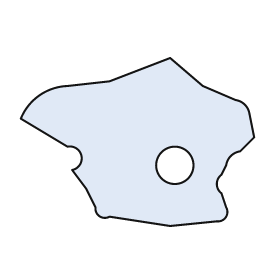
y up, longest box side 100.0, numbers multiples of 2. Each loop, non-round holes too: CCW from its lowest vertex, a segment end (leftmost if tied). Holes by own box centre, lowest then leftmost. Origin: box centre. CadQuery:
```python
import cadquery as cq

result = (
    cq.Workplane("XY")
    .moveTo(14.0, -36.0)
    .lineTo(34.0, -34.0)
    .threePointArc((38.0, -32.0), (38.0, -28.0))
    .lineTo(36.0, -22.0)
    .threePointArc((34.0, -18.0), (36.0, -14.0))
    .lineTo(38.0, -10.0)
    .threePointArc((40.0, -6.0), (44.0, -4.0))
    .lineTo(50.0, 2.0)
    .lineTo(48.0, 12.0)
    .threePointArc((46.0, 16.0), (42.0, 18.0))
    .lineTo(28.0, 24.0)
    .lineTo(14.0, 36.0)
    .lineTo(-12.0, 26.0)
    .lineTo(-30.0, 24.0)
    .threePointArc((-42.0, 20.0), (-50.0, 10.0))
    .lineTo(-30.0, -2.0)
    .threePointArc((-24.0, -6.0), (-28.0, -12.0))
    .lineTo(-22.0, -20.0)
    .lineTo(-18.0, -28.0)
    .threePointArc((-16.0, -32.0), (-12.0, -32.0))
    .close()
    .moveTo(16.0, -10.0)
    .circle(8.0)
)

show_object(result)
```